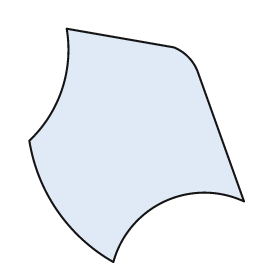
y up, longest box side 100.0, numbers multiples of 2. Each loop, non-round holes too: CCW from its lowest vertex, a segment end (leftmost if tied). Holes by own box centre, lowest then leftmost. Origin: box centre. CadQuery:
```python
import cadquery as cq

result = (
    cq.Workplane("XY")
    .moveTo(-10.0, -50.0)
    .threePointArc((12.0, -24.0), (46.0, -24.0))
    .lineTo(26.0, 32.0)
    .threePointArc((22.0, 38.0), (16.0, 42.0))
    .lineTo(-30.0, 50.0)
    .threePointArc((-32.0, 24.0), (-46.0, 2.0))
    .threePointArc((-34.0, -28.0), (-10.0, -50.0))
    .close()
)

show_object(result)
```